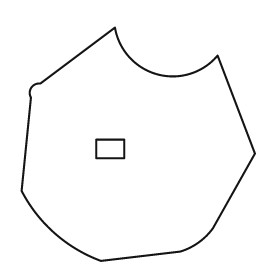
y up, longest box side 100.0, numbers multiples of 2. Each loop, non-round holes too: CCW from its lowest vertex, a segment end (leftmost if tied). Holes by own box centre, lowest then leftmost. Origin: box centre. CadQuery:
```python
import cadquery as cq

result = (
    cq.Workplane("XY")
    .moveTo(-16.0, -50.0)
    .lineTo(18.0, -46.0)
    .threePointArc((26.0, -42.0), (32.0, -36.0))
    .lineTo(50.0, -4.0)
    .lineTo(34.0, 38.0)
    .threePointArc((8.0, 30.0), (-10.0, 50.0))
    .lineTo(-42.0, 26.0)
    .threePointArc((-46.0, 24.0), (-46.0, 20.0))
    .lineTo(-50.0, -20.0)
    .threePointArc((-36.0, -38.0), (-16.0, -50.0))
    .close()
    .moveTo(-18.0, -6.0)
    .lineTo(-6.0, -6.0)
    .lineTo(-6.0, 2.0)
    .lineTo(-18.0, 2.0)
    .close()
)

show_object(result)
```